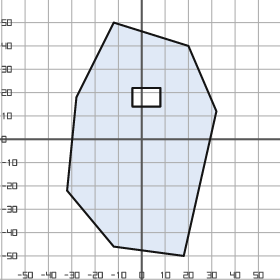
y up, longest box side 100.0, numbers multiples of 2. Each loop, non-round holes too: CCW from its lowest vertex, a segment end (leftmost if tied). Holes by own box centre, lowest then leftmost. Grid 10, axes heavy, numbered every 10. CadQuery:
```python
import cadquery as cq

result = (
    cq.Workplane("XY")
    .moveTo(18.0, -50.0)
    .lineTo(32.0, 12.0)
    .lineTo(20.0, 40.0)
    .lineTo(-12.0, 50.0)
    .lineTo(-28.0, 18.0)
    .lineTo(-32.0, -22.0)
    .lineTo(-12.0, -46.0)
    .close()
    .moveTo(-4.0, 14.0)
    .lineTo(8.0, 14.0)
    .lineTo(8.0, 22.0)
    .lineTo(-4.0, 22.0)
    .close()
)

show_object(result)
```